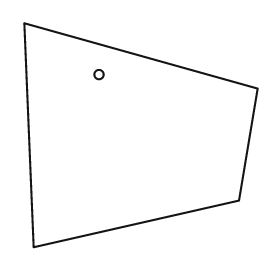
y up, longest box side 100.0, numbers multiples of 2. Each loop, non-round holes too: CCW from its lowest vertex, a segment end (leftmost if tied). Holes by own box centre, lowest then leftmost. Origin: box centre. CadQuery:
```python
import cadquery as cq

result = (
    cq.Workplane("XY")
    .moveTo(-46.0, -48.0)
    .lineTo(42.0, -28.0)
    .lineTo(50.0, 20.0)
    .lineTo(-50.0, 48.0)
    .close()
    .moveTo(-18.0, 26.0)
    .circle(2.0)
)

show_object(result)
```